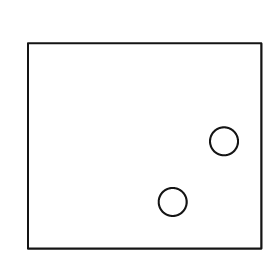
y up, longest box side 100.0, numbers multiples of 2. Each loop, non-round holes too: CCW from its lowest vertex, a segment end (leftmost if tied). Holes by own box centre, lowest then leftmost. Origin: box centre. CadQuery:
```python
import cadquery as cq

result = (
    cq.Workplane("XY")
    .moveTo(-50.0, -44.0)
    .lineTo(50.0, -44.0)
    .lineTo(50.0, 44.0)
    .lineTo(-50.0, 44.0)
    .close()
    .moveTo(12.0, -24.0)
    .circle(6.0)
    .moveTo(34.0, 2.0)
    .circle(6.0)
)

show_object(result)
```